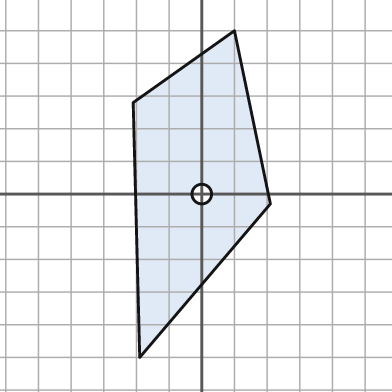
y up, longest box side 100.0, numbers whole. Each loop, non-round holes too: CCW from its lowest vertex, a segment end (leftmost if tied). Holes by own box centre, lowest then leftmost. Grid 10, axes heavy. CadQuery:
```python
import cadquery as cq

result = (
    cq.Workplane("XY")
    .moveTo(-19.0, -50.0)
    .lineTo(21.0, -3.0)
    .lineTo(10.0, 50.0)
    .lineTo(-21.0, 28.0)
    .close()
    .moveTo(0.0, 0.0)
    .circle(3.0)
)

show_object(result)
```